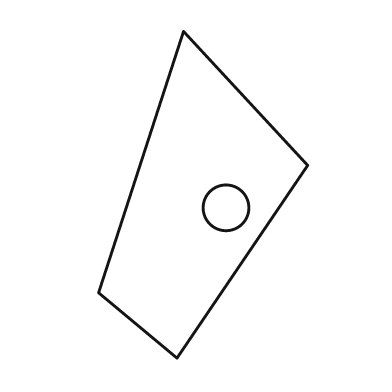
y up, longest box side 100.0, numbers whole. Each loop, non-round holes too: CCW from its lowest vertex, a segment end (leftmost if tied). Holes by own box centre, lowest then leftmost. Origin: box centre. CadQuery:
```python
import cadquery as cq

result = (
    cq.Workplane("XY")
    .moveTo(-8.0, -50.0)
    .lineTo(32.0, 9.0)
    .lineTo(-6.0, 50.0)
    .lineTo(-32.0, -30.0)
    .close()
    .moveTo(7.0, -4.0)
    .circle(7.0)
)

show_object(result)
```